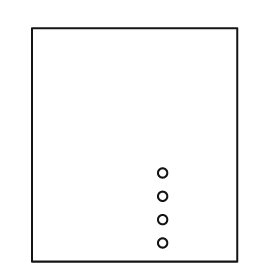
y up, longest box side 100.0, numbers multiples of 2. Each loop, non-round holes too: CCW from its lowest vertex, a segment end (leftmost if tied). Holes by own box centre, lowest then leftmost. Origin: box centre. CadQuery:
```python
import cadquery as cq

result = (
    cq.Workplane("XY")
    .moveTo(-44.0, -50.0)
    .lineTo(44.0, -50.0)
    .lineTo(44.0, 50.0)
    .lineTo(-44.0, 50.0)
    .close()
    .moveTo(12.0, -42.0)
    .circle(2.0)
    .moveTo(12.0, -32.0)
    .circle(2.0)
    .moveTo(12.0, -22.0)
    .circle(2.0)
    .moveTo(12.0, -12.0)
    .circle(2.0)
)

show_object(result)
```